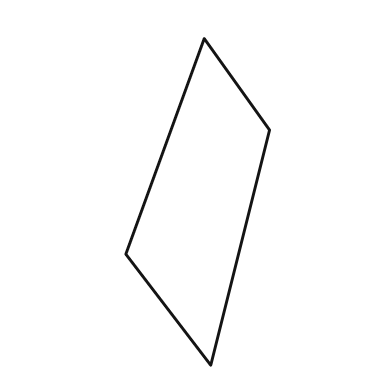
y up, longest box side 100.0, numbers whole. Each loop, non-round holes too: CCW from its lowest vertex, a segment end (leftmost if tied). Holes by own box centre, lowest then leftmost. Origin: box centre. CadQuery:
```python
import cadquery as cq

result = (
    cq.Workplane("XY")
    .moveTo(4.0, -50.0)
    .lineTo(22.0, 22.0)
    .lineTo(2.0, 50.0)
    .lineTo(-22.0, -16.0)
    .close()
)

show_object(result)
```